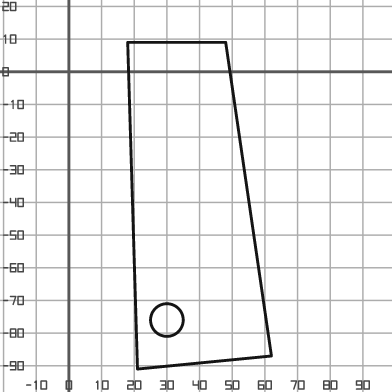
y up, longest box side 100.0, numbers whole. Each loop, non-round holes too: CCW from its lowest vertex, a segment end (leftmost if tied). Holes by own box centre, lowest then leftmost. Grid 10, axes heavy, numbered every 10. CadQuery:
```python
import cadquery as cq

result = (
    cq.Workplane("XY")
    .moveTo(21.0, -91.0)
    .lineTo(62.0, -87.0)
    .lineTo(48.0, 9.0)
    .lineTo(18.0, 9.0)
    .close()
    .moveTo(30.0, -76.0)
    .circle(5.0)
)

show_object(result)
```